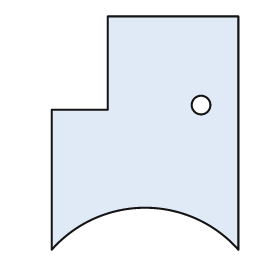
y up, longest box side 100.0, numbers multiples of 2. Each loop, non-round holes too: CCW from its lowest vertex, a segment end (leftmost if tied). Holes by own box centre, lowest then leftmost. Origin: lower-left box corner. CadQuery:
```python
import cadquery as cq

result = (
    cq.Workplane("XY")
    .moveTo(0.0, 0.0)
    .threePointArc((40.0, 18.0), (80.0, 0.0))
    .lineTo(80.0, 100.0)
    .lineTo(24.0, 100.0)
    .lineTo(24.0, 60.0)
    .lineTo(0.0, 60.0)
    .close()
    .moveTo(64.0, 62.0)
    .circle(4.0)
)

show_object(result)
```